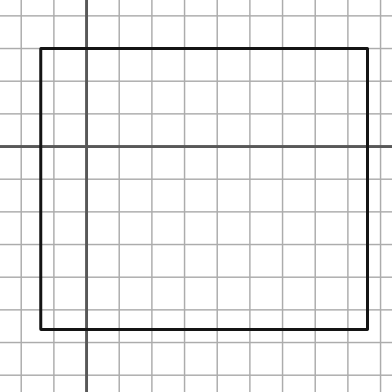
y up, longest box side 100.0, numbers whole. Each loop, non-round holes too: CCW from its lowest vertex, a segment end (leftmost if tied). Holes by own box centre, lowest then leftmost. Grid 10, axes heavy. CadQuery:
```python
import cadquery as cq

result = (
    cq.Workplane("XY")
    .moveTo(-14.0, -56.0)
    .lineTo(86.0, -56.0)
    .lineTo(86.0, 30.0)
    .lineTo(-14.0, 30.0)
    .close()
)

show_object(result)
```